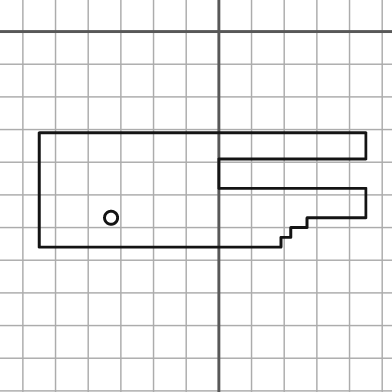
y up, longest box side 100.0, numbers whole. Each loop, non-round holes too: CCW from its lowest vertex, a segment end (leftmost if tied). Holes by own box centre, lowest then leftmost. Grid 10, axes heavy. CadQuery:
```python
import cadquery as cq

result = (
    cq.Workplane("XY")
    .moveTo(-55.0, -66.0)
    .lineTo(19.0, -66.0)
    .lineTo(19.0, -63.0)
    .lineTo(22.0, -63.0)
    .lineTo(22.0, -60.0)
    .lineTo(27.0, -60.0)
    .lineTo(27.0, -57.0)
    .lineTo(45.0, -57.0)
    .lineTo(45.0, -48.0)
    .lineTo(0.0, -48.0)
    .lineTo(0.0, -39.0)
    .lineTo(45.0, -39.0)
    .lineTo(45.0, -31.0)
    .lineTo(-55.0, -31.0)
    .close()
    .moveTo(-33.0, -57.0)
    .circle(2.0)
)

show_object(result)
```